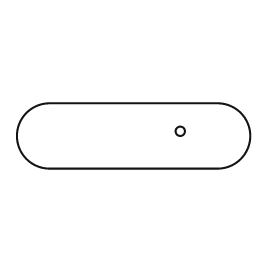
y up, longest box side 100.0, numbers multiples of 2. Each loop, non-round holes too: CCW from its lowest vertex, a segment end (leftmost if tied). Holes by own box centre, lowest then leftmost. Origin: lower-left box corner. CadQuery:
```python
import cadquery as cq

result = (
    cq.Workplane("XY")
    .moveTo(14.0, 0.0)
    .lineTo(86.0, 0.0)
    .threePointArc((100.0, 14.0), (86.0, 28.0))
    .lineTo(14.0, 28.0)
    .threePointArc((0.0, 14.0), (14.0, 0.0))
    .close()
    .moveTo(70.0, 16.0)
    .circle(2.0)
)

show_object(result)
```